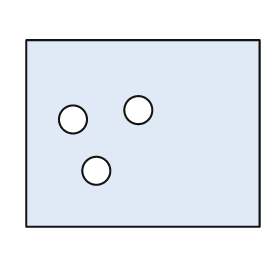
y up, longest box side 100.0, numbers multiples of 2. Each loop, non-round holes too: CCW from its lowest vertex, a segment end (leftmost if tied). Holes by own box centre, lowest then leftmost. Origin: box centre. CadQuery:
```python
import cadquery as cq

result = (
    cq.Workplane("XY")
    .moveTo(-50.0, -40.0)
    .lineTo(50.0, -40.0)
    .lineTo(50.0, 40.0)
    .lineTo(-50.0, 40.0)
    .close()
    .moveTo(-20.0, -16.0)
    .circle(6.0)
    .moveTo(-30.0, 6.0)
    .circle(6.0)
    .moveTo(-2.0, 10.0)
    .circle(6.0)
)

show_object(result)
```